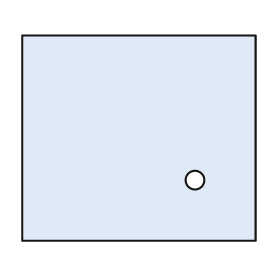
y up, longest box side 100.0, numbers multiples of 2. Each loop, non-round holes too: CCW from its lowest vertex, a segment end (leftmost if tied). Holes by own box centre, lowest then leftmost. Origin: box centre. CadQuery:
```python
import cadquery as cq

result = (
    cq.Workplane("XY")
    .moveTo(-50.0, -44.0)
    .lineTo(50.0, -44.0)
    .lineTo(50.0, 44.0)
    .lineTo(-50.0, 44.0)
    .close()
    .moveTo(24.0, -18.0)
    .circle(4.0)
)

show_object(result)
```